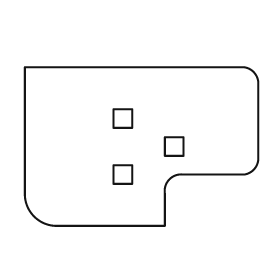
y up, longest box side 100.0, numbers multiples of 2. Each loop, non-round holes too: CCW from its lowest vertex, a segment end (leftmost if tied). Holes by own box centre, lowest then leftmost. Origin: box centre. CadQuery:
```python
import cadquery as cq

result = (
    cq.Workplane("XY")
    .moveTo(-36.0, -34.0)
    .lineTo(10.0, -34.0)
    .lineTo(10.0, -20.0)
    .threePointArc((12.0, -14.0), (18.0, -12.0))
    .lineTo(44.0, -12.0)
    .threePointArc((48.0, -10.0), (50.0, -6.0))
    .lineTo(50.0, 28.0)
    .threePointArc((48.0, 32.0), (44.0, 34.0))
    .lineTo(-50.0, 34.0)
    .lineTo(-50.0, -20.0)
    .threePointArc((-46.0, -30.0), (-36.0, -34.0))
    .close()
    .moveTo(-12.0, -16.0)
    .lineTo(-4.0, -16.0)
    .lineTo(-4.0, -8.0)
    .lineTo(-12.0, -8.0)
    .close()
    .moveTo(10.0, -4.0)
    .lineTo(18.0, -4.0)
    .lineTo(18.0, 4.0)
    .lineTo(10.0, 4.0)
    .close()
    .moveTo(-12.0, 8.0)
    .lineTo(-4.0, 8.0)
    .lineTo(-4.0, 16.0)
    .lineTo(-12.0, 16.0)
    .close()
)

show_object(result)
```